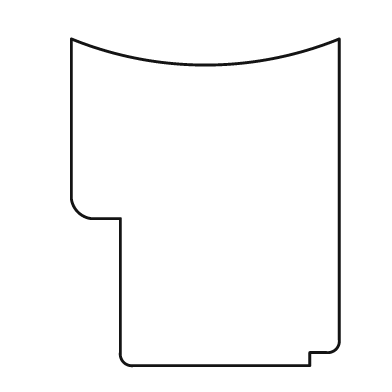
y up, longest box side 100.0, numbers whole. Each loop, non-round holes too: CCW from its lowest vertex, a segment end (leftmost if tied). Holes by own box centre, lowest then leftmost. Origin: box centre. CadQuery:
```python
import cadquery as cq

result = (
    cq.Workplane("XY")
    .moveTo(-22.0, -50.0)
    .lineTo(32.0, -50.0)
    .lineTo(32.0, -46.0)
    .lineTo(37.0, -46.0)
    .threePointArc((40.0, -45.0), (41.0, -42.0))
    .lineTo(41.0, 50.0)
    .threePointArc((0.0, 42.0), (-41.0, 50.0))
    .lineTo(-41.0, 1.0)
    .threePointArc((-39.0, -3.0), (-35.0, -5.0))
    .lineTo(-26.0, -5.0)
    .lineTo(-26.0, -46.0)
    .threePointArc((-25.0, -49.0), (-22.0, -50.0))
    .close()
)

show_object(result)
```